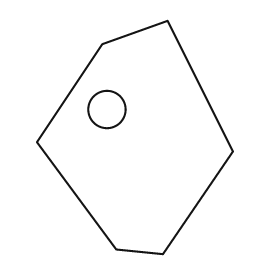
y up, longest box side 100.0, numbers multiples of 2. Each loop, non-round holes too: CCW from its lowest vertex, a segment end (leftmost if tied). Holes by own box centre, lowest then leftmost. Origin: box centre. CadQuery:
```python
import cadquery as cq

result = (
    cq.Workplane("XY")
    .moveTo(12.0, -50.0)
    .lineTo(42.0, -6.0)
    .lineTo(14.0, 50.0)
    .lineTo(-14.0, 40.0)
    .lineTo(-42.0, -2.0)
    .lineTo(-8.0, -48.0)
    .close()
    .moveTo(-12.0, 12.0)
    .circle(8.0)
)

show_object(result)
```